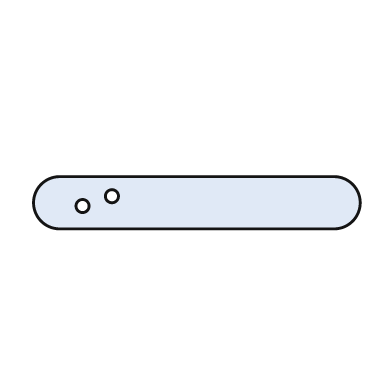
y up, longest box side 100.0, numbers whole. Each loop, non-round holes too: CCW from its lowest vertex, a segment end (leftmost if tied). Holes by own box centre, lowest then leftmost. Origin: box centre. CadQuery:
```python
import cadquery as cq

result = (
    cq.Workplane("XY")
    .moveTo(-42.0, -8.0)
    .lineTo(42.0, -8.0)
    .threePointArc((50.0, 0.0), (42.0, 8.0))
    .lineTo(-42.0, 8.0)
    .threePointArc((-50.0, 0.0), (-42.0, -8.0))
    .close()
    .moveTo(-35.0, -1.0)
    .circle(2.0)
    .moveTo(-26.0, 2.0)
    .circle(2.0)
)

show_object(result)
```